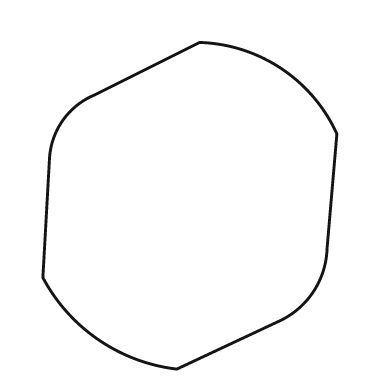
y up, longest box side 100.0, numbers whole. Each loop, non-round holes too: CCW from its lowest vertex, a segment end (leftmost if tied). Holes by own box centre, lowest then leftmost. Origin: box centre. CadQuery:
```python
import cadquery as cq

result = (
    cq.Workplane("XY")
    .moveTo(-4.0, -50.0)
    .lineTo(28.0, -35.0)
    .threePointArc((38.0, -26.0), (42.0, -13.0))
    .lineTo(45.0, 22.0)
    .threePointArc((28.0, 42.0), (3.0, 50.0))
    .lineTo(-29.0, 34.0)
    .threePointArc((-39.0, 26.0), (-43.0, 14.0))
    .lineTo(-45.0, -22.0)
    .threePointArc((-28.0, -41.0), (-4.0, -50.0))
    .close()
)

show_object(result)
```